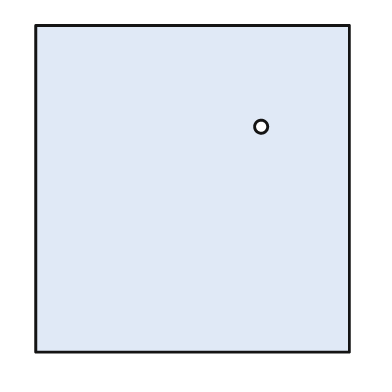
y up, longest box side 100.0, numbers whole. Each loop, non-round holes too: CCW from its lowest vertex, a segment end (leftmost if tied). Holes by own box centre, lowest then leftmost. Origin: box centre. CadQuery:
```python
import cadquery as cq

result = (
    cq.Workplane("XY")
    .moveTo(-48.0, -50.0)
    .lineTo(48.0, -50.0)
    .lineTo(48.0, 50.0)
    .lineTo(-48.0, 50.0)
    .close()
    .moveTo(21.0, 19.0)
    .circle(2.0)
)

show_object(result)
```